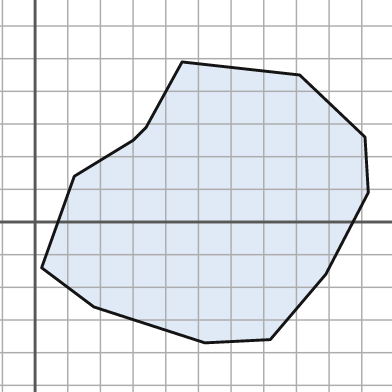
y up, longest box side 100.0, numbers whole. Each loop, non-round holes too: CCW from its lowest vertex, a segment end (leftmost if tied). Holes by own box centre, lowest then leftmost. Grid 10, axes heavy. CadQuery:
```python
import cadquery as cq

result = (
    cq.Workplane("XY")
    .moveTo(52.0, -37.0)
    .lineTo(72.0, -36.0)
    .lineTo(89.0, -16.0)
    .lineTo(102.0, 9.0)
    .lineTo(101.0, 26.0)
    .lineTo(81.0, 45.0)
    .lineTo(45.0, 49.0)
    .lineTo(34.0, 29.0)
    .lineTo(30.0, 25.0)
    .lineTo(12.0, 14.0)
    .lineTo(2.0, -14.0)
    .lineTo(18.0, -26.0)
    .close()
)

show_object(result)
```